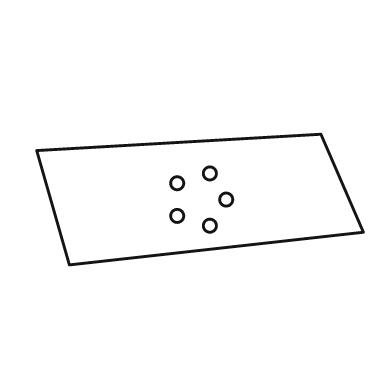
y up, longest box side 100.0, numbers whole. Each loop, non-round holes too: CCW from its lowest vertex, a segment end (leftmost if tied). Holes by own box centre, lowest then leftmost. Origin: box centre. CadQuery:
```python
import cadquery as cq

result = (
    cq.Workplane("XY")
    .moveTo(-40.0, -20.0)
    .lineTo(50.0, -10.0)
    .lineTo(37.0, 20.0)
    .lineTo(-50.0, 15.0)
    .close()
    .moveTo(3.0, -8.0)
    .circle(2.0)
    .moveTo(-7.0, -5.0)
    .circle(2.0)
    .moveTo(8.0, 0.0)
    .circle(2.0)
    .moveTo(-7.0, 5.0)
    .circle(2.0)
    .moveTo(3.0, 8.0)
    .circle(2.0)
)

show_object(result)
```